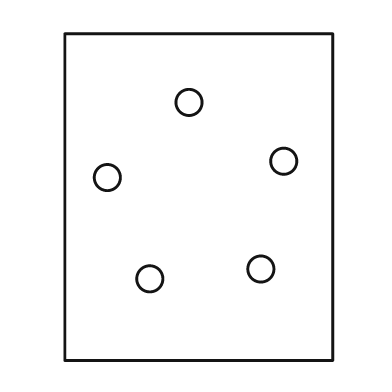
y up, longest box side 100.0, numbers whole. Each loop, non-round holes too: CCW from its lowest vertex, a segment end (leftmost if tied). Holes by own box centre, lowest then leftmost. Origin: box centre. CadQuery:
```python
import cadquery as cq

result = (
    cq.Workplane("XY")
    .moveTo(-41.0, -50.0)
    .lineTo(41.0, -50.0)
    .lineTo(41.0, 50.0)
    .lineTo(-41.0, 50.0)
    .close()
    .moveTo(-15.0, -25.0)
    .circle(4.0)
    .moveTo(19.0, -22.0)
    .circle(4.0)
    .moveTo(-28.0, 6.0)
    .circle(4.0)
    .moveTo(26.0, 11.0)
    .circle(4.0)
    .moveTo(-3.0, 29.0)
    .circle(4.0)
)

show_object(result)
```